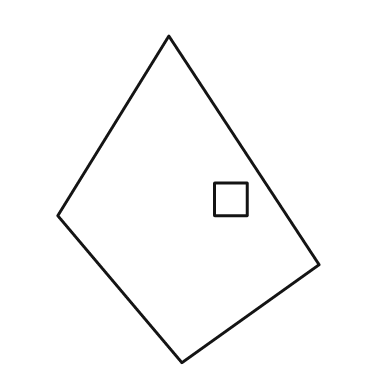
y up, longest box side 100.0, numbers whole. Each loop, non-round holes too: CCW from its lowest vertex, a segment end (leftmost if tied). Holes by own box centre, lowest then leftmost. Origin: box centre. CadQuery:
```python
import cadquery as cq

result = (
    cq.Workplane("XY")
    .moveTo(-2.0, -50.0)
    .lineTo(40.0, -20.0)
    .lineTo(-6.0, 50.0)
    .lineTo(-40.0, -5.0)
    .close()
    .moveTo(8.0, -5.0)
    .lineTo(18.0, -5.0)
    .lineTo(18.0, 5.0)
    .lineTo(8.0, 5.0)
    .close()
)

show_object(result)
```